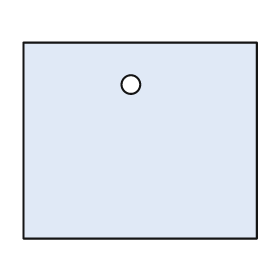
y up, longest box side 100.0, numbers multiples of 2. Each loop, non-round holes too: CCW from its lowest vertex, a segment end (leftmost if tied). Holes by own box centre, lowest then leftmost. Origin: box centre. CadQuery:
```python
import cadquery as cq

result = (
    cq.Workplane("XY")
    .moveTo(-50.0, -42.0)
    .lineTo(50.0, -42.0)
    .lineTo(50.0, 42.0)
    .lineTo(-50.0, 42.0)
    .close()
    .moveTo(-4.0, 24.0)
    .circle(4.0)
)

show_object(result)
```